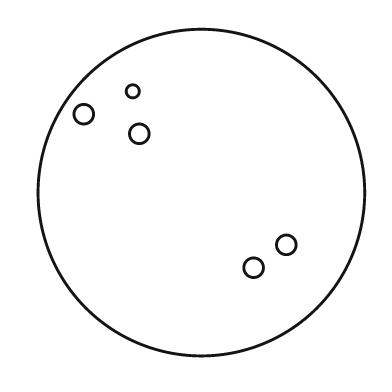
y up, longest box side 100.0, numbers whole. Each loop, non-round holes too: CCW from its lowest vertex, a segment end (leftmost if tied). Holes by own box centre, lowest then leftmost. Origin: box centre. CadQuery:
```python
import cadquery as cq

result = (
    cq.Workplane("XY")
    .moveTo(0.0, 0.0)
    .circle(50.0)
    .moveTo(16.0, -23.0)
    .circle(3.0)
    .moveTo(26.0, -16.0)
    .circle(3.0)
    .moveTo(-19.0, 18.0)
    .circle(3.0)
    .moveTo(-36.0, 24.0)
    .circle(3.0)
    .moveTo(-21.0, 31.0)
    .circle(2.0)
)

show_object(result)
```